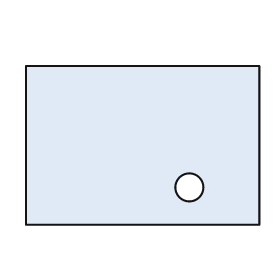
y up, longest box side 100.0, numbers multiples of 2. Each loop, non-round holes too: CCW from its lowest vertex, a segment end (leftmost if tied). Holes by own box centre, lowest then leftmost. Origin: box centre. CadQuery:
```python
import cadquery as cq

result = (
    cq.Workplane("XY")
    .moveTo(-50.0, -34.0)
    .lineTo(50.0, -34.0)
    .lineTo(50.0, 34.0)
    .lineTo(-50.0, 34.0)
    .close()
    .moveTo(20.0, -18.0)
    .circle(6.0)
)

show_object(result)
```